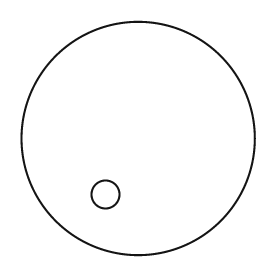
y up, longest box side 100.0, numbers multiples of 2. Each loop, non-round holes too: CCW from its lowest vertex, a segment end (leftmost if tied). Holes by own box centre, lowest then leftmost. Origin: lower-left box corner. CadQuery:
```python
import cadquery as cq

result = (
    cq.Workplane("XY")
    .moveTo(50.0, 50.0)
    .circle(50.0)
    .moveTo(36.0, 26.0)
    .circle(6.0)
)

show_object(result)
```